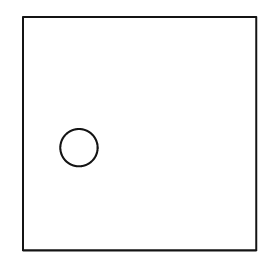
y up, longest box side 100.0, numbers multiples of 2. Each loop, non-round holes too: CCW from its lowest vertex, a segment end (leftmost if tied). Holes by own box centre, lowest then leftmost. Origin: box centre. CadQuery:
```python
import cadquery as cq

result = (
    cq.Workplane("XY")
    .moveTo(-50.0, -50.0)
    .lineTo(50.0, -50.0)
    .lineTo(50.0, 50.0)
    .lineTo(-50.0, 50.0)
    .close()
    .moveTo(-26.0, -6.0)
    .circle(8.0)
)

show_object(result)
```